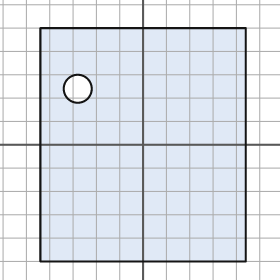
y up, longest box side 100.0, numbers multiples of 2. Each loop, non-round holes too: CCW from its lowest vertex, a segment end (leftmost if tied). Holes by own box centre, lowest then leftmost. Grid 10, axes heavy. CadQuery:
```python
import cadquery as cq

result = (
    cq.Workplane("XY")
    .moveTo(-44.0, -50.0)
    .lineTo(44.0, -50.0)
    .lineTo(44.0, 50.0)
    .lineTo(-44.0, 50.0)
    .close()
    .moveTo(-28.0, 24.0)
    .circle(6.0)
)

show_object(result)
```